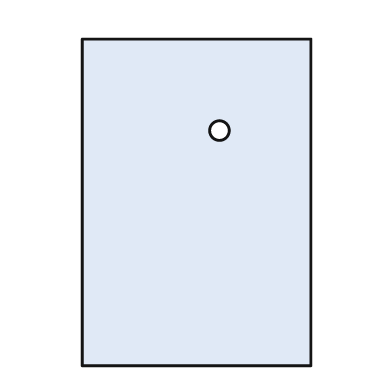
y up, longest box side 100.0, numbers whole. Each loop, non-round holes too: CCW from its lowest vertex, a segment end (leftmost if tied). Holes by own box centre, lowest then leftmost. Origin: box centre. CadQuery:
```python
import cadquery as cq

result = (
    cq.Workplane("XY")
    .moveTo(-35.0, -50.0)
    .lineTo(35.0, -50.0)
    .lineTo(35.0, 50.0)
    .lineTo(-35.0, 50.0)
    .close()
    .moveTo(7.0, 22.0)
    .circle(3.0)
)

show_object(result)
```